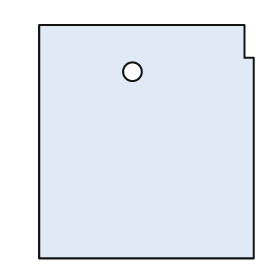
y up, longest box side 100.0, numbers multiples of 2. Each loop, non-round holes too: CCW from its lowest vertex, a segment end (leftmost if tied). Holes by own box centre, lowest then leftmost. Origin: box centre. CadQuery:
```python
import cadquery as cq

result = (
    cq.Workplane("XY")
    .moveTo(-46.0, -50.0)
    .lineTo(46.0, -50.0)
    .lineTo(46.0, 36.0)
    .lineTo(42.0, 36.0)
    .lineTo(42.0, 50.0)
    .lineTo(-46.0, 50.0)
    .close()
    .moveTo(-6.0, 30.0)
    .circle(4.0)
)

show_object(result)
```